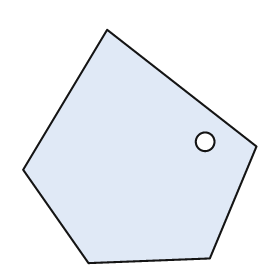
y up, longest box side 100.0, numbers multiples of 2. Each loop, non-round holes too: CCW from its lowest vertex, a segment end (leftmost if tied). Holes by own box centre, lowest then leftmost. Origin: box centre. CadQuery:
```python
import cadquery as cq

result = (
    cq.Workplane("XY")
    .moveTo(-22.0, -50.0)
    .lineTo(30.0, -48.0)
    .lineTo(50.0, 0.0)
    .lineTo(-14.0, 50.0)
    .lineTo(-50.0, -10.0)
    .close()
    .moveTo(28.0, 2.0)
    .circle(4.0)
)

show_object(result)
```